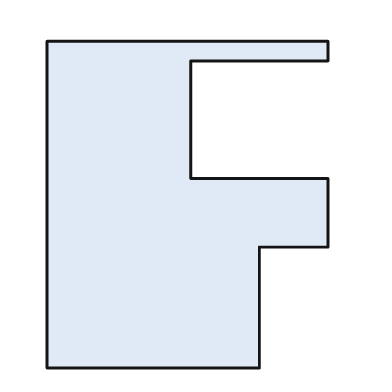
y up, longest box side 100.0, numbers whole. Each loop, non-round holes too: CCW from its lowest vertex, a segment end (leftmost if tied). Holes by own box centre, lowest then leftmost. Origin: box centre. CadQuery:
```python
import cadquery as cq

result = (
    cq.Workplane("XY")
    .moveTo(-43.0, -50.0)
    .lineTo(22.0, -50.0)
    .lineTo(22.0, -13.0)
    .lineTo(43.0, -13.0)
    .lineTo(43.0, 8.0)
    .lineTo(1.0, 8.0)
    .lineTo(1.0, 44.0)
    .lineTo(43.0, 44.0)
    .lineTo(43.0, 50.0)
    .lineTo(-43.0, 50.0)
    .close()
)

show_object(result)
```